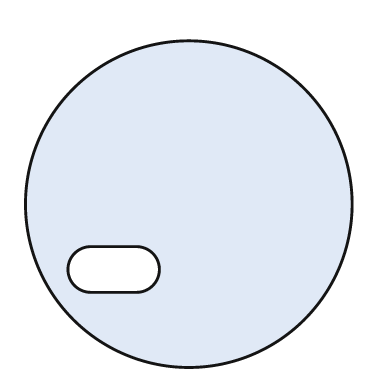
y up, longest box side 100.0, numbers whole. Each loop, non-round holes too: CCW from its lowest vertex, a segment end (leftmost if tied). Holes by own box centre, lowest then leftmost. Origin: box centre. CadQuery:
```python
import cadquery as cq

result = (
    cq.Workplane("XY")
    .moveTo(0.0, 0.0)
    .circle(50.0)
    .moveTo(-30.0, -27.0)
    .lineTo(-16.0, -27.0)
    .threePointArc((-9.0, -20.0), (-16.0, -13.0))
    .lineTo(-30.0, -13.0)
    .threePointArc((-37.0, -20.0), (-30.0, -27.0))
    .close()
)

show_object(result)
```